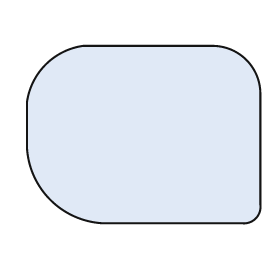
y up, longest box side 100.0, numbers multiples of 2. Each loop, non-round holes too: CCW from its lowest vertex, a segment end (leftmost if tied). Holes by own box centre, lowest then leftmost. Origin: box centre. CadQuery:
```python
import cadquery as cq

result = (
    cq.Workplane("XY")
    .moveTo(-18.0, -38.0)
    .lineTo(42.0, -38.0)
    .threePointArc((48.0, -36.0), (50.0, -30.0))
    .lineTo(50.0, 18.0)
    .threePointArc((44.0, 32.0), (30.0, 38.0))
    .lineTo(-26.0, 38.0)
    .threePointArc((-42.0, 30.0), (-50.0, 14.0))
    .lineTo(-50.0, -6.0)
    .threePointArc((-40.0, -28.0), (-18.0, -38.0))
    .close()
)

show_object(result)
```